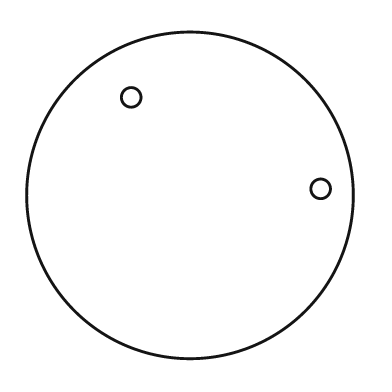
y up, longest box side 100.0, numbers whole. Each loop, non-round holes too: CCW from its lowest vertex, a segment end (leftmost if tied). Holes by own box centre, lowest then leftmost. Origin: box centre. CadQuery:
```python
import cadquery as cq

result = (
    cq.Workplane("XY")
    .moveTo(0.0, 0.0)
    .circle(50.0)
    .moveTo(40.0, 2.0)
    .circle(3.0)
    .moveTo(-18.0, 30.0)
    .circle(3.0)
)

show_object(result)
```